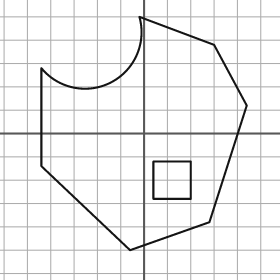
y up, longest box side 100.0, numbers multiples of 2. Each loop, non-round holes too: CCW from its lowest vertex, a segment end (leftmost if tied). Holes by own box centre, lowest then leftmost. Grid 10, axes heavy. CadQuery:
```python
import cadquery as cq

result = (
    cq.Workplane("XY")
    .moveTo(-6.0, -50.0)
    .lineTo(28.0, -38.0)
    .lineTo(44.0, 12.0)
    .lineTo(30.0, 38.0)
    .lineTo(-2.0, 50.0)
    .threePointArc((-14.0, 22.0), (-44.0, 28.0))
    .lineTo(-44.0, -14.0)
    .close()
    .moveTo(4.0, -28.0)
    .lineTo(20.0, -28.0)
    .lineTo(20.0, -12.0)
    .lineTo(4.0, -12.0)
    .close()
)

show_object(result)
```